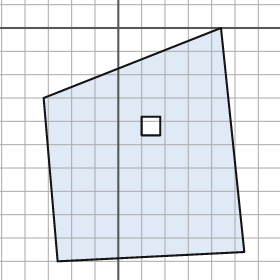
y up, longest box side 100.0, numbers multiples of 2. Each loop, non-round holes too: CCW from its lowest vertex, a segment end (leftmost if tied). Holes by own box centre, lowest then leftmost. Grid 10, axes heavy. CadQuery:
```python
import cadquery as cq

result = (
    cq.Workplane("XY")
    .moveTo(-26.0, -100.0)
    .lineTo(54.0, -96.0)
    .lineTo(44.0, 0.0)
    .lineTo(-32.0, -30.0)
    .close()
    .moveTo(10.0, -46.0)
    .lineTo(18.0, -46.0)
    .lineTo(18.0, -38.0)
    .lineTo(10.0, -38.0)
    .close()
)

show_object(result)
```